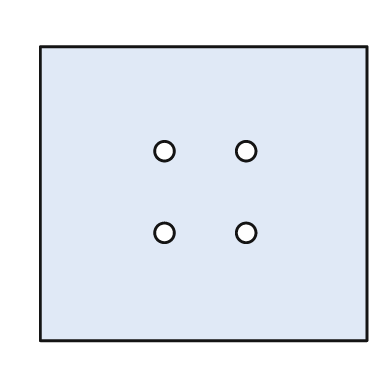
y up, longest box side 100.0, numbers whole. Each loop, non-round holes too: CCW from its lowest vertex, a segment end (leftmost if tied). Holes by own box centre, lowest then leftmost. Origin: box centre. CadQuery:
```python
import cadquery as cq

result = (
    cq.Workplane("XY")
    .moveTo(-50.0, -45.0)
    .lineTo(50.0, -45.0)
    .lineTo(50.0, 45.0)
    .lineTo(-50.0, 45.0)
    .close()
    .moveTo(-12.0, -12.0)
    .circle(3.0)
    .moveTo(13.0, -12.0)
    .circle(3.0)
    .moveTo(-12.0, 13.0)
    .circle(3.0)
    .moveTo(13.0, 13.0)
    .circle(3.0)
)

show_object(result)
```